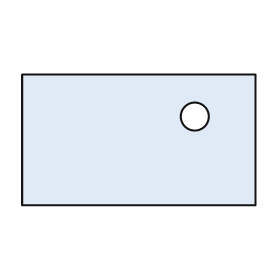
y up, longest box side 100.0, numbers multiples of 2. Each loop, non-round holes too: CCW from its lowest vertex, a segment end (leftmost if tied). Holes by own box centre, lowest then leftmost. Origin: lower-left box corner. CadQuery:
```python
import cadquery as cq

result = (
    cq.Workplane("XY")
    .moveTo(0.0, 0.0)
    .lineTo(100.0, 0.0)
    .lineTo(100.0, 56.0)
    .lineTo(0.0, 56.0)
    .close()
    .moveTo(74.0, 38.0)
    .circle(6.0)
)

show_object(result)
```